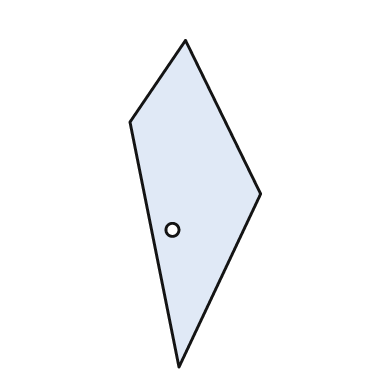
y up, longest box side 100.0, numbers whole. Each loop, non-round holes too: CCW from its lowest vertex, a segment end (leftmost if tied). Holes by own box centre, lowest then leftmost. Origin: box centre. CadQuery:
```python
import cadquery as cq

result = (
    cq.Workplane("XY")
    .moveTo(-5.0, -50.0)
    .lineTo(20.0, 3.0)
    .lineTo(-3.0, 50.0)
    .lineTo(-20.0, 25.0)
    .close()
    .moveTo(-7.0, -8.0)
    .circle(2.0)
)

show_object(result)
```